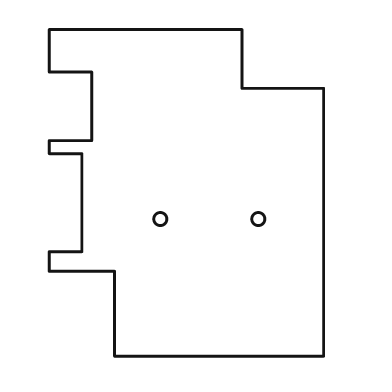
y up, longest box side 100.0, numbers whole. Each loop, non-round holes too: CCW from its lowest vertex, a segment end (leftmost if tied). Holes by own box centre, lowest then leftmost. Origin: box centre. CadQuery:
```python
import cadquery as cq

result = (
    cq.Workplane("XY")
    .moveTo(-22.0, -50.0)
    .lineTo(42.0, -50.0)
    .lineTo(42.0, 32.0)
    .lineTo(17.0, 32.0)
    .lineTo(17.0, 50.0)
    .lineTo(-42.0, 50.0)
    .lineTo(-42.0, 37.0)
    .lineTo(-29.0, 37.0)
    .lineTo(-29.0, 16.0)
    .lineTo(-42.0, 16.0)
    .lineTo(-42.0, 12.0)
    .lineTo(-32.0, 12.0)
    .lineTo(-32.0, -18.0)
    .lineTo(-42.0, -18.0)
    .lineTo(-42.0, -24.0)
    .lineTo(-22.0, -24.0)
    .close()
    .moveTo(-8.0, -8.0)
    .circle(2.0)
    .moveTo(22.0, -8.0)
    .circle(2.0)
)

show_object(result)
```